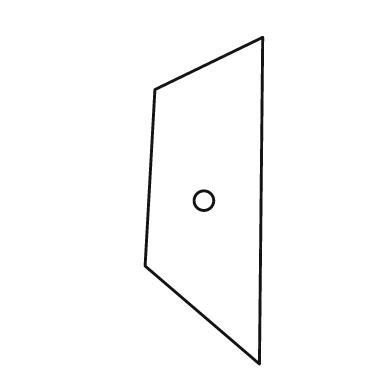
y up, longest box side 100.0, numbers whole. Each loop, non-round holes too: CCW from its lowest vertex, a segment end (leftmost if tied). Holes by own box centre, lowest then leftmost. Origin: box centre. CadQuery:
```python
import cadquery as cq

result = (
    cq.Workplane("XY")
    .moveTo(17.0, -50.0)
    .lineTo(18.0, 50.0)
    .lineTo(-15.0, 34.0)
    .lineTo(-18.0, -20.0)
    .close()
    .moveTo(0.0, 0.0)
    .circle(3.0)
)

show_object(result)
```